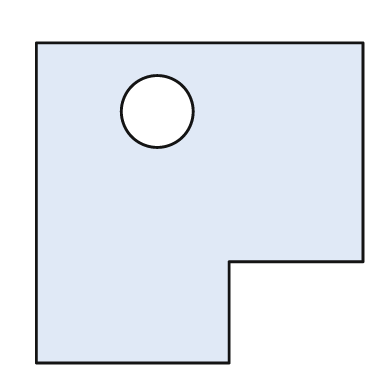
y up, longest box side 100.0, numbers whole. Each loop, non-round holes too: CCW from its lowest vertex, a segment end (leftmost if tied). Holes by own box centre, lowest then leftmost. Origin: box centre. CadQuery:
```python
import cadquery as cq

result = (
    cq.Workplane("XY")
    .moveTo(-50.0, -49.0)
    .lineTo(9.0, -49.0)
    .lineTo(9.0, -18.0)
    .lineTo(50.0, -18.0)
    .lineTo(50.0, 49.0)
    .lineTo(-50.0, 49.0)
    .close()
    .moveTo(-13.0, 28.0)
    .circle(11.0)
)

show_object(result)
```